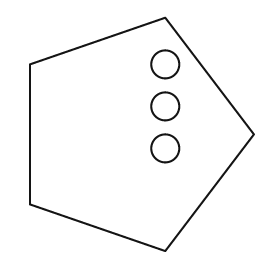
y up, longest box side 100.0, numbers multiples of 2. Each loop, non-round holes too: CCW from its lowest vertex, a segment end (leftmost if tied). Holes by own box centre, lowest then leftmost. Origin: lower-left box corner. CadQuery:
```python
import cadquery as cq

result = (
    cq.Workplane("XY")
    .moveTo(58.0, 0.0)
    .lineTo(96.0, 50.0)
    .lineTo(58.0, 100.0)
    .lineTo(0.0, 80.0)
    .lineTo(0.0, 20.0)
    .close()
    .moveTo(58.0, 44.0)
    .circle(6.0)
    .moveTo(58.0, 62.0)
    .circle(6.0)
    .moveTo(58.0, 80.0)
    .circle(6.0)
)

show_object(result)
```